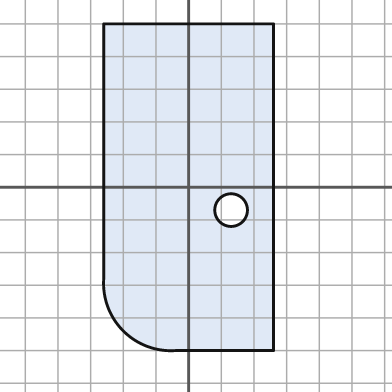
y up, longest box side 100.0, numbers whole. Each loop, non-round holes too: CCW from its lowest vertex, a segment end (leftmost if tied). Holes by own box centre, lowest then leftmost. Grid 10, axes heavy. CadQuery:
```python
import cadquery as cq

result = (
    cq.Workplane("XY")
    .moveTo(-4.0, -50.0)
    .lineTo(26.0, -50.0)
    .lineTo(26.0, 50.0)
    .lineTo(-26.0, 50.0)
    .lineTo(-26.0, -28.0)
    .threePointArc((-20.0, -44.0), (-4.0, -50.0))
    .close()
    .moveTo(13.0, -7.0)
    .circle(5.0)
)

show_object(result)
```